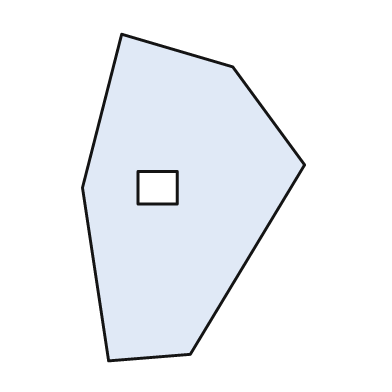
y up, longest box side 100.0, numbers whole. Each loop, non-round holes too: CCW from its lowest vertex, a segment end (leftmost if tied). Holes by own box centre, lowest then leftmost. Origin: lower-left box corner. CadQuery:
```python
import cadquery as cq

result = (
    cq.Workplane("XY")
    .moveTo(8.0, 0.0)
    .lineTo(33.0, 2.0)
    .lineTo(68.0, 60.0)
    .lineTo(46.0, 90.0)
    .lineTo(12.0, 100.0)
    .lineTo(0.0, 53.0)
    .close()
    .moveTo(17.0, 48.0)
    .lineTo(29.0, 48.0)
    .lineTo(29.0, 58.0)
    .lineTo(17.0, 58.0)
    .close()
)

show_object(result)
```